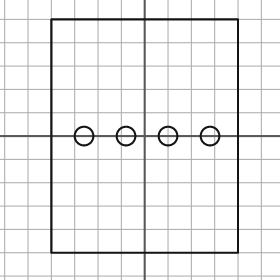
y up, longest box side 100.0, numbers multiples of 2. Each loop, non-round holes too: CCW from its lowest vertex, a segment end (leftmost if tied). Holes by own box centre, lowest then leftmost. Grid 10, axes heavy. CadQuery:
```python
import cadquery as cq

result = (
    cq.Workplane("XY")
    .moveTo(-40.0, -50.0)
    .lineTo(40.0, -50.0)
    .lineTo(40.0, 50.0)
    .lineTo(-40.0, 50.0)
    .close()
    .moveTo(-26.0, 0.0)
    .circle(4.0)
    .moveTo(-8.0, 0.0)
    .circle(4.0)
    .moveTo(10.0, 0.0)
    .circle(4.0)
    .moveTo(28.0, 0.0)
    .circle(4.0)
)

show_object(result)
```